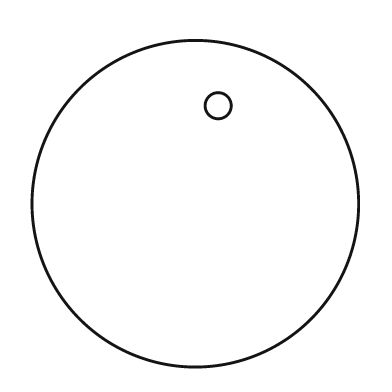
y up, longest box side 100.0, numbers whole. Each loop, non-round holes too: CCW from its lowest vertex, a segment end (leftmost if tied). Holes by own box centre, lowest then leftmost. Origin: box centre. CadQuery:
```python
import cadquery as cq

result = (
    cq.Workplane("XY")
    .moveTo(0.0, 0.0)
    .circle(50.0)
    .moveTo(7.0, 30.0)
    .circle(4.0)
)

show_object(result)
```